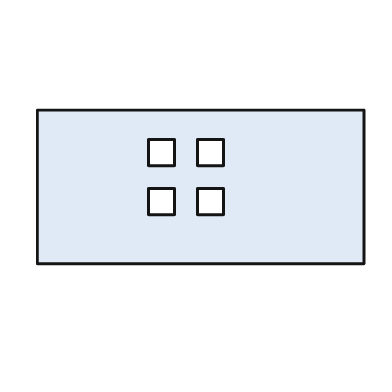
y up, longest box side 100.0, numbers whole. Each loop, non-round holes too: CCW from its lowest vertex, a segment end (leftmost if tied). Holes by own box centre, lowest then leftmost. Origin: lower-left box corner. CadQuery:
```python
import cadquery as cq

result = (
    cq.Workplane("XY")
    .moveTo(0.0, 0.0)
    .lineTo(100.0, 0.0)
    .lineTo(100.0, 47.0)
    .lineTo(0.0, 47.0)
    .close()
    .moveTo(34.0, 15.0)
    .lineTo(42.0, 15.0)
    .lineTo(42.0, 23.0)
    .lineTo(34.0, 23.0)
    .close()
    .moveTo(49.0, 15.0)
    .lineTo(57.0, 15.0)
    .lineTo(57.0, 23.0)
    .lineTo(49.0, 23.0)
    .close()
    .moveTo(34.0, 30.0)
    .lineTo(42.0, 30.0)
    .lineTo(42.0, 38.0)
    .lineTo(34.0, 38.0)
    .close()
    .moveTo(49.0, 30.0)
    .lineTo(57.0, 30.0)
    .lineTo(57.0, 38.0)
    .lineTo(49.0, 38.0)
    .close()
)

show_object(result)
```